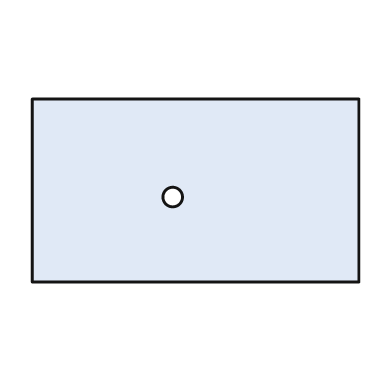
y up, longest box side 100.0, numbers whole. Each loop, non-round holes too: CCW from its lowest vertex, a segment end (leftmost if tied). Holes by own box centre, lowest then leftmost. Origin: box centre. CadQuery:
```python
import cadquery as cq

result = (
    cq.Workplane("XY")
    .moveTo(-50.0, -28.0)
    .lineTo(50.0, -28.0)
    .lineTo(50.0, 28.0)
    .lineTo(-50.0, 28.0)
    .close()
    .moveTo(-7.0, -2.0)
    .circle(3.0)
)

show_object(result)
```